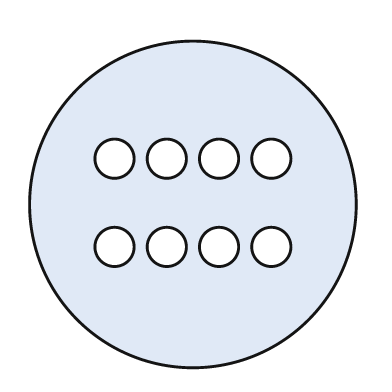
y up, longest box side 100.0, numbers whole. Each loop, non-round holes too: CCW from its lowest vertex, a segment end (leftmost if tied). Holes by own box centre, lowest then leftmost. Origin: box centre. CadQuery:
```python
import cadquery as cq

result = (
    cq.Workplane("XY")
    .moveTo(0.0, 0.0)
    .circle(50.0)
    .moveTo(-24.0, -13.0)
    .circle(6.0)
    .moveTo(-8.0, -13.0)
    .circle(6.0)
    .moveTo(8.0, -13.0)
    .circle(6.0)
    .moveTo(24.0, -13.0)
    .circle(6.0)
    .moveTo(-24.0, 14.0)
    .circle(6.0)
    .moveTo(-8.0, 14.0)
    .circle(6.0)
    .moveTo(8.0, 14.0)
    .circle(6.0)
    .moveTo(24.0, 14.0)
    .circle(6.0)
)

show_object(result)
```